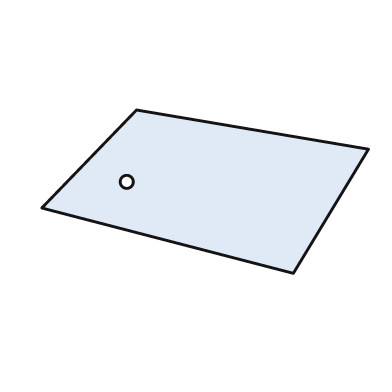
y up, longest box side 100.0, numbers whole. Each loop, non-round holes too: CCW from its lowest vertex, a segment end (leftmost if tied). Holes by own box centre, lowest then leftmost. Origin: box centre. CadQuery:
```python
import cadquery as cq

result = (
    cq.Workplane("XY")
    .moveTo(27.0, -25.0)
    .lineTo(50.0, 13.0)
    .lineTo(-21.0, 25.0)
    .lineTo(-50.0, -5.0)
    .close()
    .moveTo(-24.0, 3.0)
    .circle(2.0)
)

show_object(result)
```